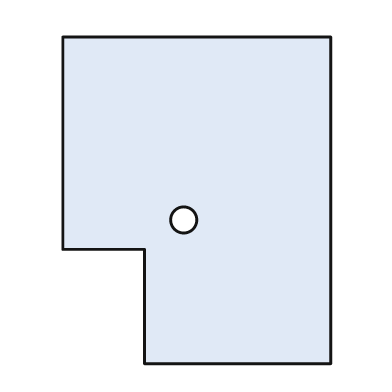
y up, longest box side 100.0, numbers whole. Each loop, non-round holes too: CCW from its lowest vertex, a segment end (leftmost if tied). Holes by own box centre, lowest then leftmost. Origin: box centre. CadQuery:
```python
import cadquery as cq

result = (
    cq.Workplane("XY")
    .moveTo(-16.0, -50.0)
    .lineTo(41.0, -50.0)
    .lineTo(41.0, 50.0)
    .lineTo(-41.0, 50.0)
    .lineTo(-41.0, -15.0)
    .lineTo(-16.0, -15.0)
    .close()
    .moveTo(-4.0, -6.0)
    .circle(4.0)
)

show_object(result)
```